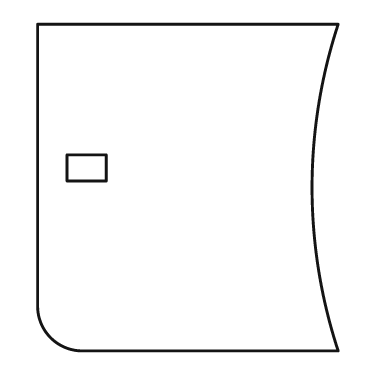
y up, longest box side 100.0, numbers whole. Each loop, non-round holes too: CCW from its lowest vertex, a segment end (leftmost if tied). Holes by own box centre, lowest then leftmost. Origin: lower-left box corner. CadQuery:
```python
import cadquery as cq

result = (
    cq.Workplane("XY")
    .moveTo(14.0, 0.0)
    .lineTo(92.0, 0.0)
    .threePointArc((84.0, 50.0), (92.0, 100.0))
    .lineTo(0.0, 100.0)
    .lineTo(0.0, 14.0)
    .threePointArc((4.0, 4.0), (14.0, 0.0))
    .close()
    .moveTo(9.0, 52.0)
    .lineTo(21.0, 52.0)
    .lineTo(21.0, 60.0)
    .lineTo(9.0, 60.0)
    .close()
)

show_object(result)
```